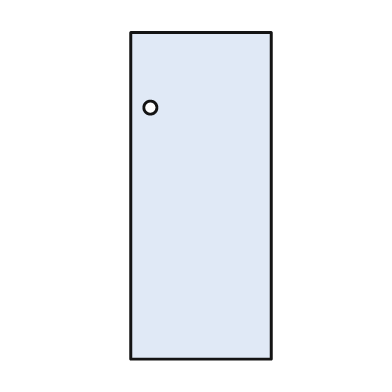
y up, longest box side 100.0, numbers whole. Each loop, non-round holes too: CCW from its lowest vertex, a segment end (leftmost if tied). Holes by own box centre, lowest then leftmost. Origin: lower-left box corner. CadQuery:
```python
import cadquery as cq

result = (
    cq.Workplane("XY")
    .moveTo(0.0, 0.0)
    .lineTo(43.0, 0.0)
    .lineTo(43.0, 100.0)
    .lineTo(0.0, 100.0)
    .close()
    .moveTo(6.0, 77.0)
    .circle(2.0)
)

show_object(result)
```